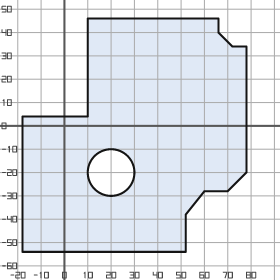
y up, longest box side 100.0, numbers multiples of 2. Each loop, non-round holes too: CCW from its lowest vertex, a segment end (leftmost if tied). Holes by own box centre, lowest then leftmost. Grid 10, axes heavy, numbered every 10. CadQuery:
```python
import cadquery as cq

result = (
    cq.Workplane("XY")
    .moveTo(-18.0, -54.0)
    .lineTo(52.0, -54.0)
    .lineTo(52.0, -38.0)
    .lineTo(60.0, -28.0)
    .lineTo(70.0, -28.0)
    .lineTo(78.0, -20.0)
    .lineTo(78.0, 34.0)
    .lineTo(72.0, 34.0)
    .lineTo(66.0, 40.0)
    .lineTo(66.0, 46.0)
    .lineTo(10.0, 46.0)
    .lineTo(10.0, 4.0)
    .lineTo(-18.0, 4.0)
    .close()
    .moveTo(20.0, -20.0)
    .circle(10.0)
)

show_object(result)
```